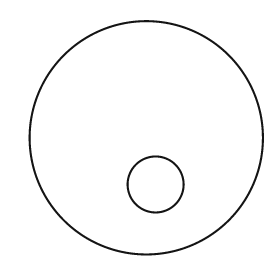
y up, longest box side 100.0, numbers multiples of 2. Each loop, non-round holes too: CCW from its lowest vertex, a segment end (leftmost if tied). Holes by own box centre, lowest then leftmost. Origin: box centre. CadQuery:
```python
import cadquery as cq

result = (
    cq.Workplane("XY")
    .moveTo(0.0, 0.0)
    .circle(50.0)
    .moveTo(4.0, -20.0)
    .circle(12.0)
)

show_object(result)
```